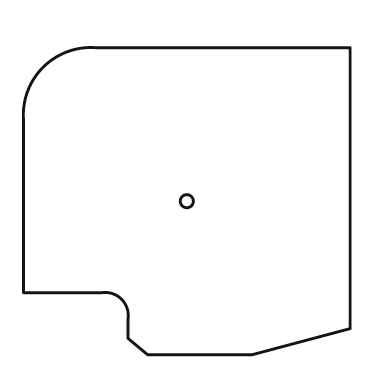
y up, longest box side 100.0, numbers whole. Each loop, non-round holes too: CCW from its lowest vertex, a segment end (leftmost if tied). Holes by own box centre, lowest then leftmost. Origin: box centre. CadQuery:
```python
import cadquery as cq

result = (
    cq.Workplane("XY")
    .moveTo(-12.0, -47.0)
    .lineTo(20.0, -47.0)
    .lineTo(50.0, -39.0)
    .lineTo(50.0, 47.0)
    .lineTo(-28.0, 47.0)
    .threePointArc((-44.0, 41.0), (-50.0, 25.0))
    .lineTo(-50.0, -28.0)
    .lineTo(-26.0, -28.0)
    .threePointArc((-20.0, -30.0), (-18.0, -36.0))
    .lineTo(-18.0, -42.0)
    .close()
    .moveTo(0.0, 0.0)
    .circle(2.0)
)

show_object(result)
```